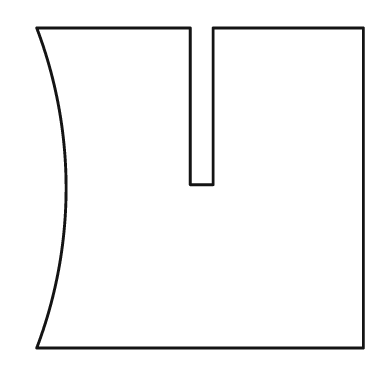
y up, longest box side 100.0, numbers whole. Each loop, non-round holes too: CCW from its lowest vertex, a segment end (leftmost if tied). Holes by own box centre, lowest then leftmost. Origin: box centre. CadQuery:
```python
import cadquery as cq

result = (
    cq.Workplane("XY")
    .moveTo(-50.0, -49.0)
    .lineTo(50.0, -49.0)
    .lineTo(50.0, 49.0)
    .lineTo(4.0, 49.0)
    .lineTo(4.0, 1.0)
    .lineTo(-3.0, 1.0)
    .lineTo(-3.0, 49.0)
    .lineTo(-50.0, 49.0)
    .threePointArc((-41.0, 0.0), (-50.0, -49.0))
    .close()
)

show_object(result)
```